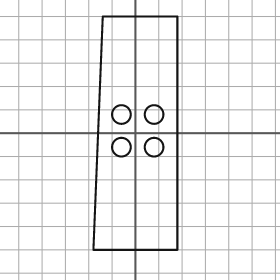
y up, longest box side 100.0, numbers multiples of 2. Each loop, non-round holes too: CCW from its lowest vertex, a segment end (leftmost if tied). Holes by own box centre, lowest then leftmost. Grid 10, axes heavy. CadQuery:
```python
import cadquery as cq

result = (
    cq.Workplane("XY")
    .moveTo(-18.0, -50.0)
    .lineTo(18.0, -50.0)
    .lineTo(18.0, 50.0)
    .lineTo(-14.0, 50.0)
    .close()
    .moveTo(-6.0, -6.0)
    .circle(4.0)
    .moveTo(8.0, -6.0)
    .circle(4.0)
    .moveTo(-6.0, 8.0)
    .circle(4.0)
    .moveTo(8.0, 8.0)
    .circle(4.0)
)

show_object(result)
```